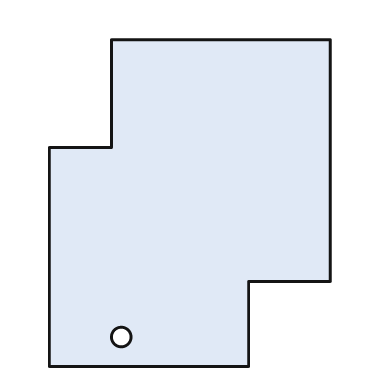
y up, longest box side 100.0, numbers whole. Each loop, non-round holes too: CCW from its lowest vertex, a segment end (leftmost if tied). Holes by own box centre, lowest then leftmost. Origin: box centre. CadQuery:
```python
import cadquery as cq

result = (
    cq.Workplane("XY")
    .moveTo(-43.0, -50.0)
    .lineTo(18.0, -50.0)
    .lineTo(18.0, -24.0)
    .lineTo(43.0, -24.0)
    .lineTo(43.0, 50.0)
    .lineTo(-24.0, 50.0)
    .lineTo(-24.0, 17.0)
    .lineTo(-43.0, 17.0)
    .close()
    .moveTo(-21.0, -41.0)
    .circle(3.0)
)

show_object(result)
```